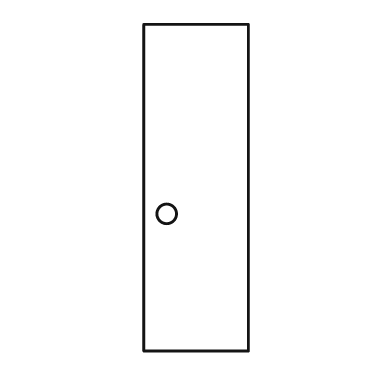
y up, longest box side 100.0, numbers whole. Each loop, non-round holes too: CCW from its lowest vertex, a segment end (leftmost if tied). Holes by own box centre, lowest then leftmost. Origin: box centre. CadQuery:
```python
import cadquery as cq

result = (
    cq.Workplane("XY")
    .moveTo(-16.0, -50.0)
    .lineTo(16.0, -50.0)
    .lineTo(16.0, 50.0)
    .lineTo(-16.0, 50.0)
    .close()
    .moveTo(-9.0, -8.0)
    .circle(3.0)
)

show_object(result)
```